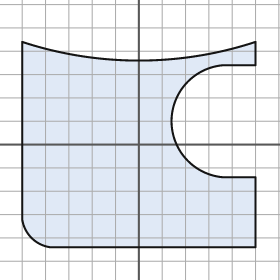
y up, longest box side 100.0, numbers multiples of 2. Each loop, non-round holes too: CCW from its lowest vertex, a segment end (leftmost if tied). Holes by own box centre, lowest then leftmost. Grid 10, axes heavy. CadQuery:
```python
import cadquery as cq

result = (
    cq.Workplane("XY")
    .moveTo(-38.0, -44.0)
    .lineTo(50.0, -44.0)
    .lineTo(50.0, -14.0)
    .lineTo(36.0, -14.0)
    .threePointArc((14.0, 10.0), (36.0, 34.0))
    .lineTo(50.0, 34.0)
    .lineTo(50.0, 44.0)
    .threePointArc((0.0, 36.0), (-50.0, 44.0))
    .lineTo(-50.0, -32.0)
    .threePointArc((-46.0, -40.0), (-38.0, -44.0))
    .close()
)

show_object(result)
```